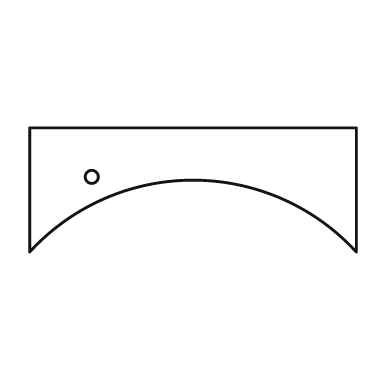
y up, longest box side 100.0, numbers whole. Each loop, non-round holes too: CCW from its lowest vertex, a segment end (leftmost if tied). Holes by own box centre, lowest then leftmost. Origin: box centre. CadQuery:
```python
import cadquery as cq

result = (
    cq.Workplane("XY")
    .moveTo(-50.0, -19.0)
    .threePointArc((0.0, 3.0), (50.0, -19.0))
    .lineTo(50.0, 19.0)
    .lineTo(-50.0, 19.0)
    .close()
    .moveTo(-31.0, 4.0)
    .circle(2.0)
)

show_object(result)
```